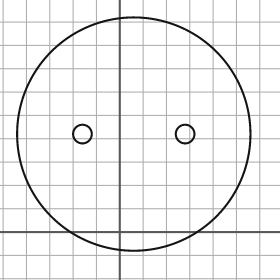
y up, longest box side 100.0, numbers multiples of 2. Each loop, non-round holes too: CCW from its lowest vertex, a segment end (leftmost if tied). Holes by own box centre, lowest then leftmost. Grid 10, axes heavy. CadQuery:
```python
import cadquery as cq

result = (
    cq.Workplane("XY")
    .moveTo(6.0, 42.0)
    .circle(50.0)
    .moveTo(-16.0, 42.0)
    .circle(4.0)
    .moveTo(28.0, 42.0)
    .circle(4.0)
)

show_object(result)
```